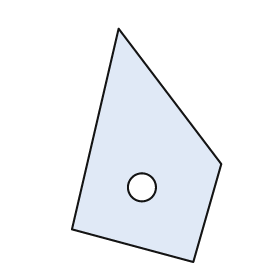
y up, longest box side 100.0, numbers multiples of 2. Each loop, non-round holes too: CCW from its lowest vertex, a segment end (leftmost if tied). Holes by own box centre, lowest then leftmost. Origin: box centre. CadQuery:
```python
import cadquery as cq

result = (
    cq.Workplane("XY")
    .moveTo(20.0, -50.0)
    .lineTo(32.0, -8.0)
    .lineTo(-12.0, 50.0)
    .lineTo(-32.0, -36.0)
    .close()
    .moveTo(-2.0, -18.0)
    .circle(6.0)
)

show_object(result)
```